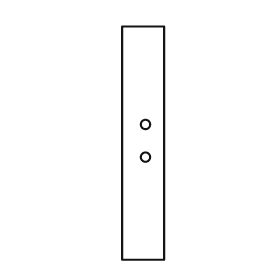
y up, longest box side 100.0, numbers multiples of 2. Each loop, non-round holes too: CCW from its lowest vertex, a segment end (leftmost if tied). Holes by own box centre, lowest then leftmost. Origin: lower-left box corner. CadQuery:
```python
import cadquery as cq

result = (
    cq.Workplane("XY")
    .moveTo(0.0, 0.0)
    .lineTo(18.0, 0.0)
    .lineTo(18.0, 100.0)
    .lineTo(0.0, 100.0)
    .close()
    .moveTo(10.0, 44.0)
    .circle(2.0)
    .moveTo(10.0, 58.0)
    .circle(2.0)
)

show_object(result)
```